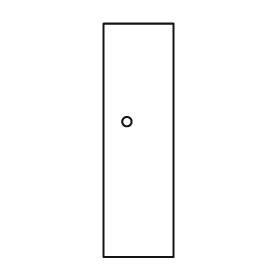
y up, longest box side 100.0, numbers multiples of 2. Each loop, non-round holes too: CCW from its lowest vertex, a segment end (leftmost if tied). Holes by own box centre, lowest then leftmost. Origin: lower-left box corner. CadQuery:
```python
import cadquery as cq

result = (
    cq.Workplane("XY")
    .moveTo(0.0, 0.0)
    .lineTo(30.0, 0.0)
    .lineTo(30.0, 100.0)
    .lineTo(0.0, 100.0)
    .close()
    .moveTo(10.0, 58.0)
    .circle(2.0)
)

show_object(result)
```